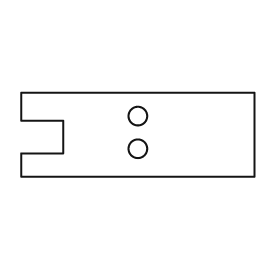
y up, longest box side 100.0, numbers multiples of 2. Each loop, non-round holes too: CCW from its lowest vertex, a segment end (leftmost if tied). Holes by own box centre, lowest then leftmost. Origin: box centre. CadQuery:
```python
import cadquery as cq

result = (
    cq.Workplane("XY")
    .moveTo(-50.0, -18.0)
    .lineTo(50.0, -18.0)
    .lineTo(50.0, 18.0)
    .lineTo(-50.0, 18.0)
    .lineTo(-50.0, 6.0)
    .lineTo(-32.0, 6.0)
    .lineTo(-32.0, -8.0)
    .lineTo(-50.0, -8.0)
    .close()
    .moveTo(0.0, -6.0)
    .circle(4.0)
    .moveTo(0.0, 8.0)
    .circle(4.0)
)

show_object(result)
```